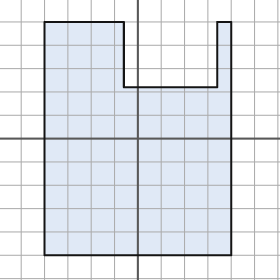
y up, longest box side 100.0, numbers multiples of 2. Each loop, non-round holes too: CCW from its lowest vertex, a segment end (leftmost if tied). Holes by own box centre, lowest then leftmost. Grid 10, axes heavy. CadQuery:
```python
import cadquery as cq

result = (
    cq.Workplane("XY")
    .moveTo(-40.0, -50.0)
    .lineTo(40.0, -50.0)
    .lineTo(40.0, 50.0)
    .lineTo(34.0, 50.0)
    .lineTo(34.0, 22.0)
    .lineTo(-6.0, 22.0)
    .lineTo(-6.0, 50.0)
    .lineTo(-40.0, 50.0)
    .close()
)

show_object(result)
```